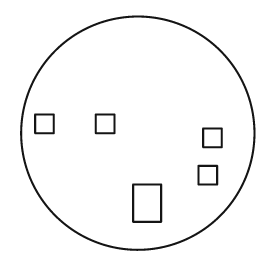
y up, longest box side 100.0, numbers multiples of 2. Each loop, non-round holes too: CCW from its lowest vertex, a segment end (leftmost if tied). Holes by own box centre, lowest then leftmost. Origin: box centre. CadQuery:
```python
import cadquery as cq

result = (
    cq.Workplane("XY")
    .moveTo(0.0, 0.0)
    .circle(50.0)
    .moveTo(-2.0, -38.0)
    .lineTo(10.0, -38.0)
    .lineTo(10.0, -22.0)
    .lineTo(-2.0, -22.0)
    .close()
    .moveTo(26.0, -22.0)
    .lineTo(34.0, -22.0)
    .lineTo(34.0, -14.0)
    .lineTo(26.0, -14.0)
    .close()
    .moveTo(28.0, -6.0)
    .lineTo(36.0, -6.0)
    .lineTo(36.0, 2.0)
    .lineTo(28.0, 2.0)
    .close()
    .moveTo(-44.0, 0.0)
    .lineTo(-36.0, 0.0)
    .lineTo(-36.0, 8.0)
    .lineTo(-44.0, 8.0)
    .close()
    .moveTo(-18.0, 0.0)
    .lineTo(-10.0, 0.0)
    .lineTo(-10.0, 8.0)
    .lineTo(-18.0, 8.0)
    .close()
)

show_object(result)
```